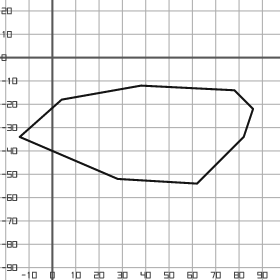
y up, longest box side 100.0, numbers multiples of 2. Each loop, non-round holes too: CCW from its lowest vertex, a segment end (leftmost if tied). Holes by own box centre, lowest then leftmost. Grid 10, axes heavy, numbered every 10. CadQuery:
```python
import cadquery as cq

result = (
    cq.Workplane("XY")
    .moveTo(62.0, -54.0)
    .lineTo(82.0, -34.0)
    .lineTo(86.0, -22.0)
    .lineTo(78.0, -14.0)
    .lineTo(38.0, -12.0)
    .lineTo(4.0, -18.0)
    .lineTo(-14.0, -34.0)
    .lineTo(28.0, -52.0)
    .close()
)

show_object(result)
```